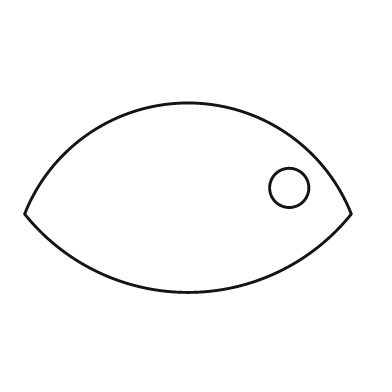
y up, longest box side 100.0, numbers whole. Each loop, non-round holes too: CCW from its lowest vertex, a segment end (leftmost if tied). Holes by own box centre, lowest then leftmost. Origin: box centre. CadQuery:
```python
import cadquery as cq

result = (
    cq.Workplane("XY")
    .moveTo(-50.0, -5.0)
    .threePointArc((0.0, -29.0), (50.0, -5.0))
    .threePointArc((0.0, 29.0), (-50.0, -5.0))
    .close()
    .moveTo(31.0, 3.0)
    .circle(6.0)
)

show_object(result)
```